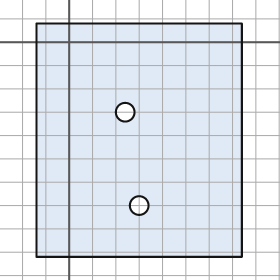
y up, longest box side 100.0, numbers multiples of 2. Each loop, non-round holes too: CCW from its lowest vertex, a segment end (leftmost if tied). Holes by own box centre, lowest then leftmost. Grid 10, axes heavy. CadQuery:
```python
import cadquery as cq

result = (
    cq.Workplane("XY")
    .moveTo(-14.0, -92.0)
    .lineTo(74.0, -92.0)
    .lineTo(74.0, 8.0)
    .lineTo(-14.0, 8.0)
    .close()
    .moveTo(30.0, -70.0)
    .circle(4.0)
    .moveTo(24.0, -30.0)
    .circle(4.0)
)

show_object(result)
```